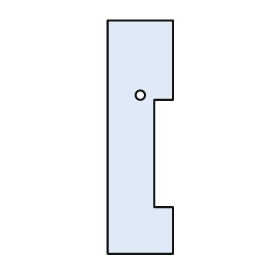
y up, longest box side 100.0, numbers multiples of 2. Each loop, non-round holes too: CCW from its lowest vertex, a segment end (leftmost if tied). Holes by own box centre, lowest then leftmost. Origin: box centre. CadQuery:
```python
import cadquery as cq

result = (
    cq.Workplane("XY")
    .moveTo(-14.0, -50.0)
    .lineTo(14.0, -50.0)
    .lineTo(14.0, -30.0)
    .lineTo(6.0, -30.0)
    .lineTo(6.0, 16.0)
    .lineTo(14.0, 16.0)
    .lineTo(14.0, 50.0)
    .lineTo(-14.0, 50.0)
    .close()
    .moveTo(0.0, 18.0)
    .circle(2.0)
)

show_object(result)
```